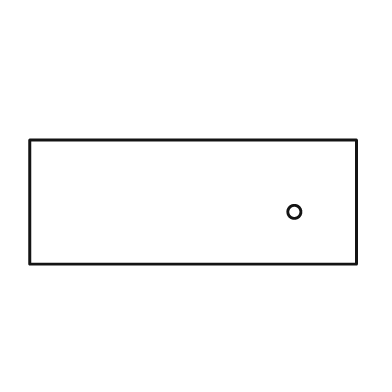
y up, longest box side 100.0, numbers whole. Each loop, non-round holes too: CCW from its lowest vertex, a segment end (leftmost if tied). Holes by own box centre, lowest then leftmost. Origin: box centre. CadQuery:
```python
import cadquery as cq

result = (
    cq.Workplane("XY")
    .moveTo(-50.0, -19.0)
    .lineTo(50.0, -19.0)
    .lineTo(50.0, 19.0)
    .lineTo(-50.0, 19.0)
    .close()
    .moveTo(31.0, -3.0)
    .circle(2.0)
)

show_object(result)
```